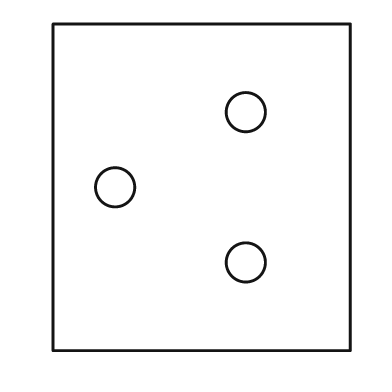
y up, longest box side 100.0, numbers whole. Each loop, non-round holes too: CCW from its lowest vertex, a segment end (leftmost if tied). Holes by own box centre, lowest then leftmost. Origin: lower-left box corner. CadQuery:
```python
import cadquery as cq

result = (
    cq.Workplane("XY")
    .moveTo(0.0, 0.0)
    .lineTo(91.0, 0.0)
    .lineTo(91.0, 100.0)
    .lineTo(0.0, 100.0)
    .close()
    .moveTo(59.0, 27.0)
    .circle(6.0)
    .moveTo(19.0, 50.0)
    .circle(6.0)
    .moveTo(59.0, 73.0)
    .circle(6.0)
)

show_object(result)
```